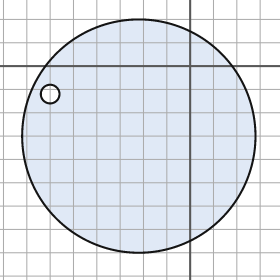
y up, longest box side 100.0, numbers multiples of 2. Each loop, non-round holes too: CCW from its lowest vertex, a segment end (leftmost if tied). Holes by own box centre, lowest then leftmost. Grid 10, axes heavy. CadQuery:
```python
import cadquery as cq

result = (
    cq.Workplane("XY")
    .moveTo(-22.0, -30.0)
    .circle(50.0)
    .moveTo(-60.0, -12.0)
    .circle(4.0)
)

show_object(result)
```